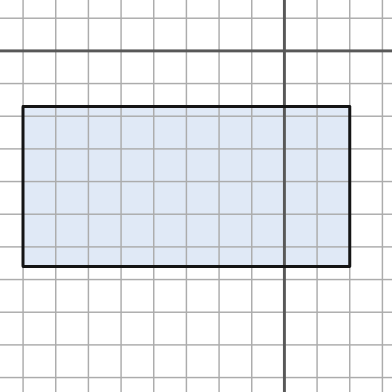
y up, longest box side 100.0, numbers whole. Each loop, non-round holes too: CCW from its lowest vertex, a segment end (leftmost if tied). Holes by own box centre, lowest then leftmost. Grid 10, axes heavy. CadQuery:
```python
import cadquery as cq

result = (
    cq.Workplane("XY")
    .moveTo(-80.0, -66.0)
    .lineTo(20.0, -66.0)
    .lineTo(20.0, -17.0)
    .lineTo(-80.0, -17.0)
    .close()
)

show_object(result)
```